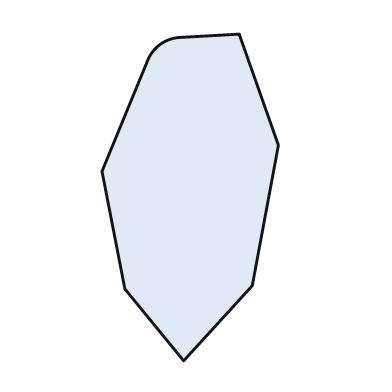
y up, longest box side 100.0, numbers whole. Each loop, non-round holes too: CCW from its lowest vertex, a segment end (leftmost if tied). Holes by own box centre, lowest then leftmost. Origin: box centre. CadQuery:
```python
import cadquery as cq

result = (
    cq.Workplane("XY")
    .moveTo(-2.0, -50.0)
    .lineTo(19.0, -27.0)
    .lineTo(27.0, 16.0)
    .lineTo(15.0, 50.0)
    .lineTo(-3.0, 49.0)
    .threePointArc((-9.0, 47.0), (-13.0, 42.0))
    .lineTo(-27.0, 8.0)
    .lineTo(-20.0, -28.0)
    .close()
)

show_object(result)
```